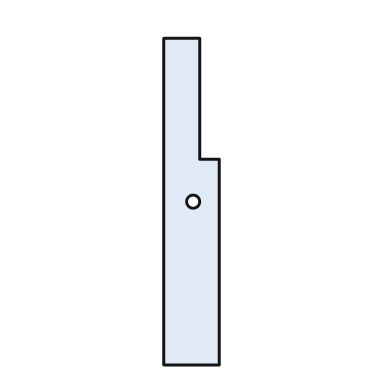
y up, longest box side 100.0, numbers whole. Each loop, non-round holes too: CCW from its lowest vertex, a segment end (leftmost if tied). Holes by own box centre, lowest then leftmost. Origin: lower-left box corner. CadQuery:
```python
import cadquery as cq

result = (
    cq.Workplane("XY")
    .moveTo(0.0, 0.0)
    .lineTo(17.0, 0.0)
    .lineTo(17.0, 63.0)
    .lineTo(11.0, 63.0)
    .lineTo(11.0, 100.0)
    .lineTo(0.0, 100.0)
    .close()
    .moveTo(9.0, 50.0)
    .circle(2.0)
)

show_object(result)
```